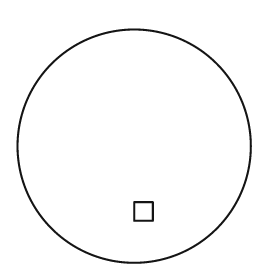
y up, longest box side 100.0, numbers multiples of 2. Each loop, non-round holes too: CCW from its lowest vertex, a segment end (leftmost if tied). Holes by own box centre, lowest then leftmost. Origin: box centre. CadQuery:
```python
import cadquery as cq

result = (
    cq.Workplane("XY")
    .moveTo(0.0, 0.0)
    .circle(50.0)
    .moveTo(0.0, -32.0)
    .lineTo(8.0, -32.0)
    .lineTo(8.0, -24.0)
    .lineTo(0.0, -24.0)
    .close()
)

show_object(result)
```